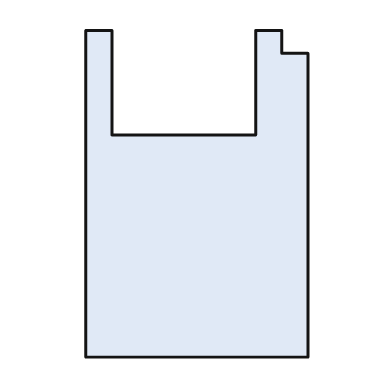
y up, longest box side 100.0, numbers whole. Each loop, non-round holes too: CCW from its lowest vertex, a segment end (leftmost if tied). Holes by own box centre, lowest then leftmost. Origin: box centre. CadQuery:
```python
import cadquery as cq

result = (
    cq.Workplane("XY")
    .moveTo(-34.0, -50.0)
    .lineTo(34.0, -50.0)
    .lineTo(34.0, 43.0)
    .lineTo(26.0, 43.0)
    .lineTo(26.0, 50.0)
    .lineTo(18.0, 50.0)
    .lineTo(18.0, 18.0)
    .lineTo(-26.0, 18.0)
    .lineTo(-26.0, 50.0)
    .lineTo(-34.0, 50.0)
    .close()
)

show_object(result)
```